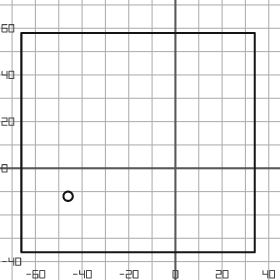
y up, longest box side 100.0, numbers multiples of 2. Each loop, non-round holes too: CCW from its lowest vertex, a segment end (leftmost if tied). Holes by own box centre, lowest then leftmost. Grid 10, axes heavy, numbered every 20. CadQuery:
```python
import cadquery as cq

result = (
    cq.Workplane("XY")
    .moveTo(-66.0, -36.0)
    .lineTo(34.0, -36.0)
    .lineTo(34.0, 58.0)
    .lineTo(-66.0, 58.0)
    .close()
    .moveTo(-46.0, -12.0)
    .circle(2.0)
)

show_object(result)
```